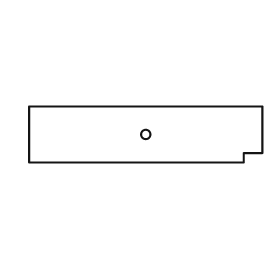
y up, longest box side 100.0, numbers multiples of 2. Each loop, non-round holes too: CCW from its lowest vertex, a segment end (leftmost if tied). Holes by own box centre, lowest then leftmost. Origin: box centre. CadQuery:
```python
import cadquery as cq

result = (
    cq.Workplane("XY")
    .moveTo(-50.0, -12.0)
    .lineTo(42.0, -12.0)
    .lineTo(42.0, -8.0)
    .lineTo(50.0, -8.0)
    .lineTo(50.0, 12.0)
    .lineTo(-50.0, 12.0)
    .close()
    .moveTo(0.0, 0.0)
    .circle(2.0)
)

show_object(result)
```